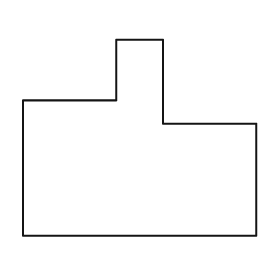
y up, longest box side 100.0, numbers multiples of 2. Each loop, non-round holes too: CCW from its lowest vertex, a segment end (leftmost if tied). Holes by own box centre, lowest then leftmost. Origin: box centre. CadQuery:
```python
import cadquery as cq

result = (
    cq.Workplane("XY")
    .moveTo(-50.0, -42.0)
    .lineTo(50.0, -42.0)
    .lineTo(50.0, 6.0)
    .lineTo(10.0, 6.0)
    .lineTo(10.0, 42.0)
    .lineTo(-10.0, 42.0)
    .lineTo(-10.0, 16.0)
    .lineTo(-50.0, 16.0)
    .close()
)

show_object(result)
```